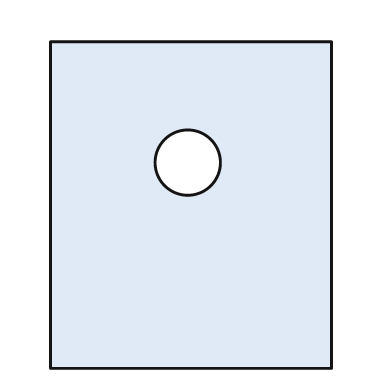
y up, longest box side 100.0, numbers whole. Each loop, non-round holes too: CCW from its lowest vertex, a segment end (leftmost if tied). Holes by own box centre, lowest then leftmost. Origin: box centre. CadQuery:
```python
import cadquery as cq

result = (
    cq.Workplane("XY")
    .moveTo(-43.0, -50.0)
    .lineTo(43.0, -50.0)
    .lineTo(43.0, 50.0)
    .lineTo(-43.0, 50.0)
    .close()
    .moveTo(-1.0, 13.0)
    .circle(10.0)
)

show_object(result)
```